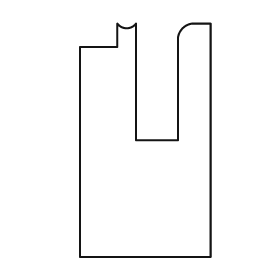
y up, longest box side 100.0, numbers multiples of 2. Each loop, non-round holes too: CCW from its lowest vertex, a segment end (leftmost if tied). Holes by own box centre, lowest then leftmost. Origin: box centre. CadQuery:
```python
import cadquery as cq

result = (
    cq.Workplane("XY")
    .moveTo(-28.0, -50.0)
    .lineTo(28.0, -50.0)
    .lineTo(28.0, 50.0)
    .lineTo(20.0, 50.0)
    .threePointArc((16.0, 48.0), (14.0, 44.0))
    .lineTo(14.0, 0.0)
    .lineTo(-4.0, 0.0)
    .lineTo(-4.0, 50.0)
    .threePointArc((-8.0, 48.0), (-12.0, 50.0))
    .lineTo(-12.0, 40.0)
    .lineTo(-28.0, 40.0)
    .close()
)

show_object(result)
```